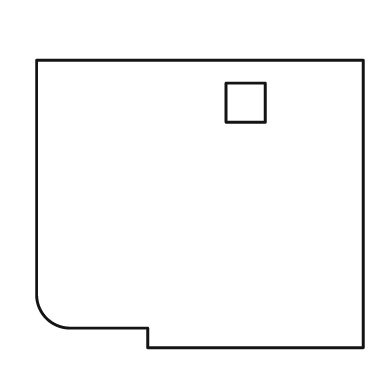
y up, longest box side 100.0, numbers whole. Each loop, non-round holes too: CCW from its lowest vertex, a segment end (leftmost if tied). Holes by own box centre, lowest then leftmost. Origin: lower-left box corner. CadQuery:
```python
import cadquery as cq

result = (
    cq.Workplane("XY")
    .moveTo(34.0, 0.0)
    .lineTo(100.0, 0.0)
    .lineTo(100.0, 88.0)
    .lineTo(0.0, 88.0)
    .lineTo(0.0, 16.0)
    .threePointArc((3.0, 9.0), (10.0, 6.0))
    .lineTo(34.0, 6.0)
    .close()
    .moveTo(58.0, 69.0)
    .lineTo(70.0, 69.0)
    .lineTo(70.0, 81.0)
    .lineTo(58.0, 81.0)
    .close()
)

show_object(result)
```